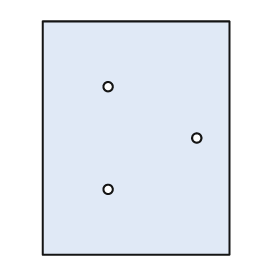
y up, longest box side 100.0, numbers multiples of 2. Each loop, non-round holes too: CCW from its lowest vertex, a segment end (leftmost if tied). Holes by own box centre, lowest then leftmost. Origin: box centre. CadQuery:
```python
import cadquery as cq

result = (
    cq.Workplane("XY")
    .moveTo(-40.0, -50.0)
    .lineTo(40.0, -50.0)
    .lineTo(40.0, 50.0)
    .lineTo(-40.0, 50.0)
    .close()
    .moveTo(-12.0, -22.0)
    .circle(2.0)
    .moveTo(26.0, 0.0)
    .circle(2.0)
    .moveTo(-12.0, 22.0)
    .circle(2.0)
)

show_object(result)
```